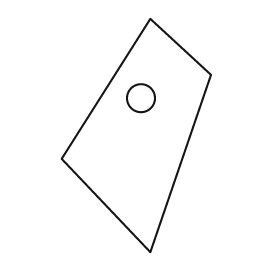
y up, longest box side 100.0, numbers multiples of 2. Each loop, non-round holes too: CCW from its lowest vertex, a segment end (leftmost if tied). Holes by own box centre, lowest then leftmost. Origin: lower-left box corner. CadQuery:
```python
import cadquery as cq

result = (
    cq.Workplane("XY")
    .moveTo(38.0, 0.0)
    .lineTo(64.0, 76.0)
    .lineTo(38.0, 100.0)
    .lineTo(0.0, 40.0)
    .close()
    .moveTo(34.0, 66.0)
    .circle(6.0)
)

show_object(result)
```